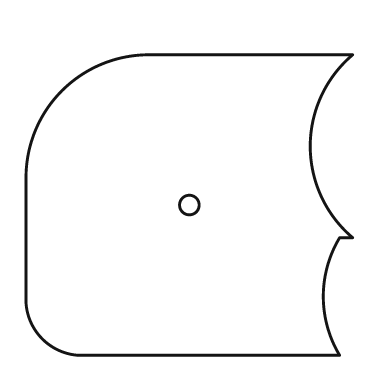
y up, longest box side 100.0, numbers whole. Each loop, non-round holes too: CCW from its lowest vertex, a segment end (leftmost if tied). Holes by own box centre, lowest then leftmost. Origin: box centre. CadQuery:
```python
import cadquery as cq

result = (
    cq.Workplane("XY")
    .moveTo(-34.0, -46.0)
    .lineTo(46.0, -46.0)
    .threePointArc((41.0, -28.0), (46.0, -10.0))
    .lineTo(50.0, -10.0)
    .threePointArc((37.0, 18.0), (50.0, 46.0))
    .lineTo(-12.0, 46.0)
    .threePointArc((-39.0, 35.0), (-50.0, 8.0))
    .lineTo(-50.0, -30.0)
    .threePointArc((-45.0, -41.0), (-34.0, -46.0))
    .close()
    .moveTo(0.0, 0.0)
    .circle(3.0)
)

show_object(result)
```